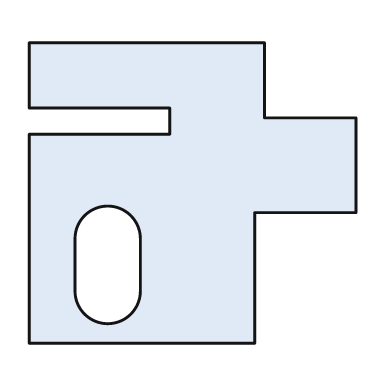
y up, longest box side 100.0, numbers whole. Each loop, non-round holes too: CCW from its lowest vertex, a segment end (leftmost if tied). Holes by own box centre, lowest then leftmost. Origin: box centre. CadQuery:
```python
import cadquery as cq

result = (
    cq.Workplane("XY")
    .moveTo(-50.0, -46.0)
    .lineTo(19.0, -46.0)
    .lineTo(19.0, -6.0)
    .lineTo(50.0, -6.0)
    .lineTo(50.0, 23.0)
    .lineTo(22.0, 23.0)
    .lineTo(22.0, 46.0)
    .lineTo(-50.0, 46.0)
    .lineTo(-50.0, 26.0)
    .lineTo(-7.0, 26.0)
    .lineTo(-7.0, 18.0)
    .lineTo(-50.0, 18.0)
    .close()
    .moveTo(-36.0, -30.0)
    .threePointArc((-26.0, -40.0), (-16.0, -30.0))
    .lineTo(-16.0, -14.0)
    .threePointArc((-26.0, -4.0), (-36.0, -14.0))
    .close()
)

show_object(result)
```